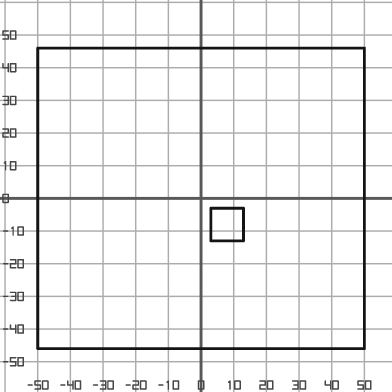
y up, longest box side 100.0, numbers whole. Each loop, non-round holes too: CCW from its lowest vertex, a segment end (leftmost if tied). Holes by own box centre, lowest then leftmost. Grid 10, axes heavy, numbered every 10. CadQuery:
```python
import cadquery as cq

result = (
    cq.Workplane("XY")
    .moveTo(-50.0, -46.0)
    .lineTo(50.0, -46.0)
    .lineTo(50.0, 46.0)
    .lineTo(-50.0, 46.0)
    .close()
    .moveTo(3.0, -13.0)
    .lineTo(13.0, -13.0)
    .lineTo(13.0, -3.0)
    .lineTo(3.0, -3.0)
    .close()
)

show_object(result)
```